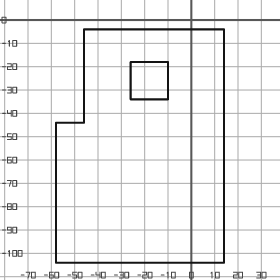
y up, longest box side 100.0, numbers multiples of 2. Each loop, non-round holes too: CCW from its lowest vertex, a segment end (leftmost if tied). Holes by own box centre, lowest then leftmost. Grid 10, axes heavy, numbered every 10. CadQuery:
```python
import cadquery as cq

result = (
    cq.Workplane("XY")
    .moveTo(-58.0, -104.0)
    .lineTo(14.0, -104.0)
    .lineTo(14.0, -4.0)
    .lineTo(-46.0, -4.0)
    .lineTo(-46.0, -44.0)
    .lineTo(-58.0, -44.0)
    .close()
    .moveTo(-26.0, -34.0)
    .lineTo(-10.0, -34.0)
    .lineTo(-10.0, -18.0)
    .lineTo(-26.0, -18.0)
    .close()
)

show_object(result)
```